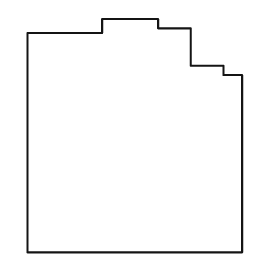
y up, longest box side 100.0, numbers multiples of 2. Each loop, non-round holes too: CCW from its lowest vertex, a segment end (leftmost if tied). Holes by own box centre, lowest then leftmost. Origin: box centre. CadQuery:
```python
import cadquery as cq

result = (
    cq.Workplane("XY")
    .moveTo(-46.0, -50.0)
    .lineTo(46.0, -50.0)
    .lineTo(46.0, 26.0)
    .lineTo(38.0, 26.0)
    .lineTo(38.0, 30.0)
    .lineTo(24.0, 30.0)
    .lineTo(24.0, 46.0)
    .lineTo(10.0, 46.0)
    .lineTo(10.0, 50.0)
    .lineTo(-14.0, 50.0)
    .lineTo(-14.0, 44.0)
    .lineTo(-46.0, 44.0)
    .close()
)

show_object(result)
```